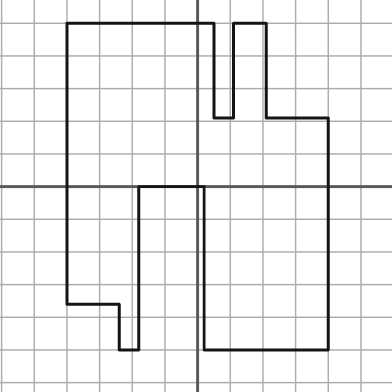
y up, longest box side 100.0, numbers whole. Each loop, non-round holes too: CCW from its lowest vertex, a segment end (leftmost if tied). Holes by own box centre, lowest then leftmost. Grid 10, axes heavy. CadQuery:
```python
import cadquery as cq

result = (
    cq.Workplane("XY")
    .moveTo(-24.0, -50.0)
    .lineTo(-18.0, -50.0)
    .lineTo(-18.0, 0.0)
    .lineTo(2.0, 0.0)
    .lineTo(2.0, -50.0)
    .lineTo(40.0, -50.0)
    .lineTo(40.0, 21.0)
    .lineTo(21.0, 21.0)
    .lineTo(21.0, 50.0)
    .lineTo(11.0, 50.0)
    .lineTo(11.0, 21.0)
    .lineTo(5.0, 21.0)
    .lineTo(5.0, 50.0)
    .lineTo(-40.0, 50.0)
    .lineTo(-40.0, -36.0)
    .lineTo(-24.0, -36.0)
    .close()
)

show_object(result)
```